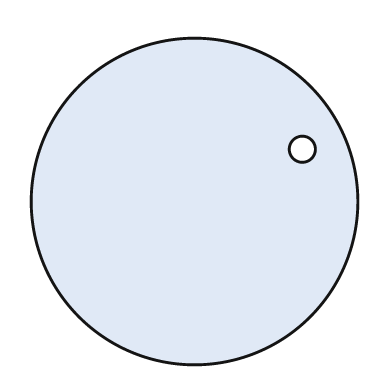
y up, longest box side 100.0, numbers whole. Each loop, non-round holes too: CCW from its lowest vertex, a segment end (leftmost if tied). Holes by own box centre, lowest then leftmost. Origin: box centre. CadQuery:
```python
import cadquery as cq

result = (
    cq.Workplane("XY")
    .moveTo(0.0, 0.0)
    .circle(50.0)
    .moveTo(33.0, 16.0)
    .circle(4.0)
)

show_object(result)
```